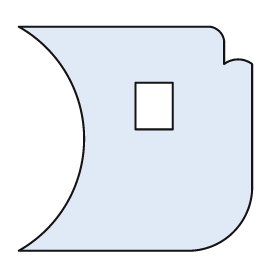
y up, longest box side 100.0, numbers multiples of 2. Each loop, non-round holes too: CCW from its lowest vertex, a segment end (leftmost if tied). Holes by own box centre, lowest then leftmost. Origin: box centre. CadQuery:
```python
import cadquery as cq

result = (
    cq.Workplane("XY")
    .moveTo(-50.0, -48.0)
    .lineTo(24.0, -48.0)
    .threePointArc((42.0, -40.0), (50.0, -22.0))
    .lineTo(50.0, 32.0)
    .threePointArc((44.0, 34.0), (38.0, 32.0))
    .lineTo(38.0, 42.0)
    .threePointArc((36.0, 46.0), (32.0, 48.0))
    .lineTo(-50.0, 48.0)
    .threePointArc((-22.0, 0.0), (-50.0, -48.0))
    .close()
    .moveTo(0.0, 4.0)
    .lineTo(16.0, 4.0)
    .lineTo(16.0, 24.0)
    .lineTo(0.0, 24.0)
    .close()
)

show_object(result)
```